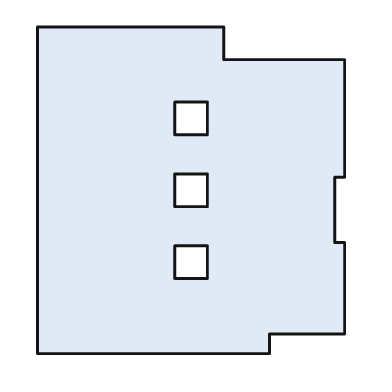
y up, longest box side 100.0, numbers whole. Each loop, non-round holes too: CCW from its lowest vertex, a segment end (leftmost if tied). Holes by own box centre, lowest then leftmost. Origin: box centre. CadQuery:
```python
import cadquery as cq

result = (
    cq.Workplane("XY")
    .moveTo(-47.0, -50.0)
    .lineTo(24.0, -50.0)
    .lineTo(24.0, -44.0)
    .lineTo(47.0, -44.0)
    .lineTo(47.0, -16.0)
    .lineTo(44.0, -16.0)
    .lineTo(44.0, 4.0)
    .lineTo(47.0, 4.0)
    .lineTo(47.0, 40.0)
    .lineTo(10.0, 40.0)
    .lineTo(10.0, 50.0)
    .lineTo(-47.0, 50.0)
    .close()
    .moveTo(-5.0, -27.0)
    .lineTo(5.0, -27.0)
    .lineTo(5.0, -17.0)
    .lineTo(-5.0, -17.0)
    .close()
    .moveTo(-5.0, -5.0)
    .lineTo(5.0, -5.0)
    .lineTo(5.0, 5.0)
    .lineTo(-5.0, 5.0)
    .close()
    .moveTo(-5.0, 17.0)
    .lineTo(5.0, 17.0)
    .lineTo(5.0, 27.0)
    .lineTo(-5.0, 27.0)
    .close()
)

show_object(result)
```